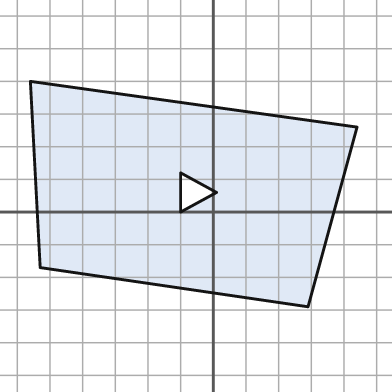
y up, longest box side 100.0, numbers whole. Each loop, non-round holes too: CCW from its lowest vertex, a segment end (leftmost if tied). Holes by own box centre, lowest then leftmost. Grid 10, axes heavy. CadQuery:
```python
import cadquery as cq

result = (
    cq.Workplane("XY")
    .moveTo(29.0, -29.0)
    .lineTo(44.0, 26.0)
    .lineTo(-56.0, 40.0)
    .lineTo(-53.0, -17.0)
    .close()
    .moveTo(-10.0, 0.0)
    .lineTo(1.0, 6.0)
    .lineTo(-10.0, 12.0)
    .close()
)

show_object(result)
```